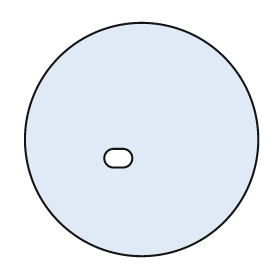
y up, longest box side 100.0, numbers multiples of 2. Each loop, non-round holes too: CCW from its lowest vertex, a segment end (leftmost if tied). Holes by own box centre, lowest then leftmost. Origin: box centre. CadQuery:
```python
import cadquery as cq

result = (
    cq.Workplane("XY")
    .moveTo(0.0, 0.0)
    .circle(50.0)
    .moveTo(-12.0, -12.0)
    .lineTo(-8.0, -12.0)
    .threePointArc((-4.0, -8.0), (-8.0, -4.0))
    .lineTo(-12.0, -4.0)
    .threePointArc((-16.0, -8.0), (-12.0, -12.0))
    .close()
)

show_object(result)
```